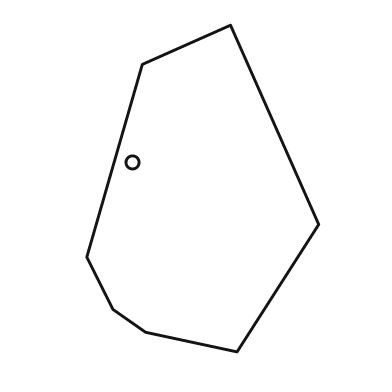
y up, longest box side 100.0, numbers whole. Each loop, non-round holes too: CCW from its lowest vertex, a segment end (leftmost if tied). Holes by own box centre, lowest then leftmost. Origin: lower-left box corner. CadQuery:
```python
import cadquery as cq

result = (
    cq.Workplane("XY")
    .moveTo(46.0, 0.0)
    .lineTo(71.0, 39.0)
    .lineTo(44.0, 100.0)
    .lineTo(17.0, 88.0)
    .lineTo(0.0, 29.0)
    .lineTo(8.0, 13.0)
    .lineTo(18.0, 6.0)
    .close()
    .moveTo(14.0, 58.0)
    .circle(2.0)
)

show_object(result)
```